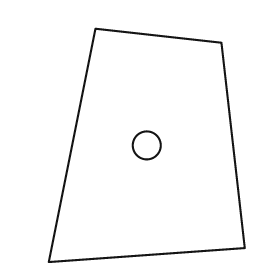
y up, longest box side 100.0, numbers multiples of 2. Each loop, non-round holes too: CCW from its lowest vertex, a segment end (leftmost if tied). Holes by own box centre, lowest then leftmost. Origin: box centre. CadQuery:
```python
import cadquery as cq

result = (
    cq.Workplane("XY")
    .moveTo(-42.0, -50.0)
    .lineTo(42.0, -44.0)
    .lineTo(32.0, 44.0)
    .lineTo(-22.0, 50.0)
    .close()
    .moveTo(0.0, 0.0)
    .circle(6.0)
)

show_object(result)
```